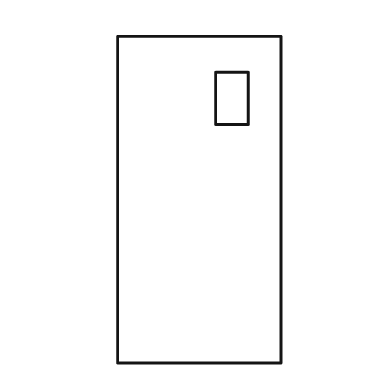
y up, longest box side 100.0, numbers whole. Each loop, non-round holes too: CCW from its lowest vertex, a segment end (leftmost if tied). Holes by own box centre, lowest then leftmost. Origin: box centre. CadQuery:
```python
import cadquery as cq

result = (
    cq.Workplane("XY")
    .moveTo(-25.0, -50.0)
    .lineTo(25.0, -50.0)
    .lineTo(25.0, 50.0)
    .lineTo(-25.0, 50.0)
    .close()
    .moveTo(5.0, 23.0)
    .lineTo(15.0, 23.0)
    .lineTo(15.0, 39.0)
    .lineTo(5.0, 39.0)
    .close()
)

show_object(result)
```